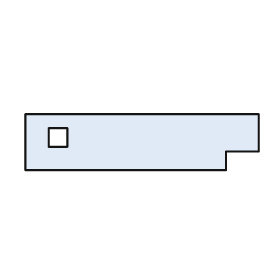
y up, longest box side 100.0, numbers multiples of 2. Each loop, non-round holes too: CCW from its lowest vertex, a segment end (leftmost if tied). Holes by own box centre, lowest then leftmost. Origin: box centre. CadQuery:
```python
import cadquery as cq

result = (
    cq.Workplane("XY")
    .moveTo(-50.0, -12.0)
    .lineTo(36.0, -12.0)
    .lineTo(36.0, -4.0)
    .lineTo(50.0, -4.0)
    .lineTo(50.0, 12.0)
    .lineTo(-50.0, 12.0)
    .close()
    .moveTo(-40.0, -2.0)
    .lineTo(-32.0, -2.0)
    .lineTo(-32.0, 6.0)
    .lineTo(-40.0, 6.0)
    .close()
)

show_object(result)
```